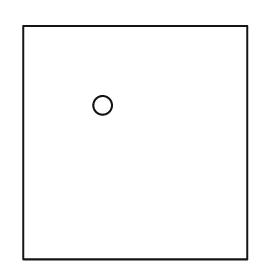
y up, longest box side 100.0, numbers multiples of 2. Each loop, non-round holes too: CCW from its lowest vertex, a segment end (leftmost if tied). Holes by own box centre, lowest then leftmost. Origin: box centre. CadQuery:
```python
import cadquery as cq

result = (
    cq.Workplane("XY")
    .moveTo(-48.0, -50.0)
    .lineTo(48.0, -50.0)
    .lineTo(48.0, 50.0)
    .lineTo(-48.0, 50.0)
    .close()
    .moveTo(-14.0, 16.0)
    .circle(4.0)
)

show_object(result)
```